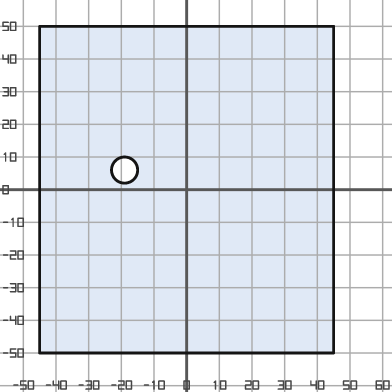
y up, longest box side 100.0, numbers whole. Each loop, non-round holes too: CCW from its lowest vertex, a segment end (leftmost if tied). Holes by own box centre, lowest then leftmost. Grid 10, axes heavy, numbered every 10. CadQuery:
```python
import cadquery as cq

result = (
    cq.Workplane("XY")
    .moveTo(-45.0, -50.0)
    .lineTo(45.0, -50.0)
    .lineTo(45.0, 50.0)
    .lineTo(-45.0, 50.0)
    .close()
    .moveTo(-19.0, 6.0)
    .circle(4.0)
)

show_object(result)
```